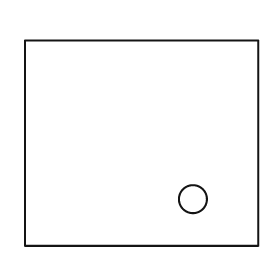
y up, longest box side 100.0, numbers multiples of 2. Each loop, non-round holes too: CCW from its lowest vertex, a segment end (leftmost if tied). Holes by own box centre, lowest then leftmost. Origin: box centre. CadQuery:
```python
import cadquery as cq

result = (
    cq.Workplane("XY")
    .moveTo(-50.0, -44.0)
    .lineTo(50.0, -44.0)
    .lineTo(50.0, 44.0)
    .lineTo(-50.0, 44.0)
    .close()
    .moveTo(22.0, -24.0)
    .circle(6.0)
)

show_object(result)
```